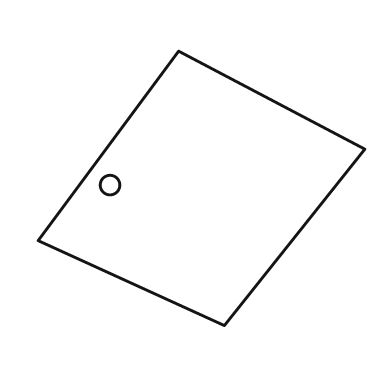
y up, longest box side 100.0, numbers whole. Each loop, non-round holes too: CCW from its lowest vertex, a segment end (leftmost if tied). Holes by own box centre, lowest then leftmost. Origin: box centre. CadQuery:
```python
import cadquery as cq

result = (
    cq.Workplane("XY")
    .moveTo(7.0, -42.0)
    .lineTo(50.0, 12.0)
    .lineTo(-7.0, 42.0)
    .lineTo(-50.0, -16.0)
    .close()
    .moveTo(-28.0, 1.0)
    .circle(3.0)
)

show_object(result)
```